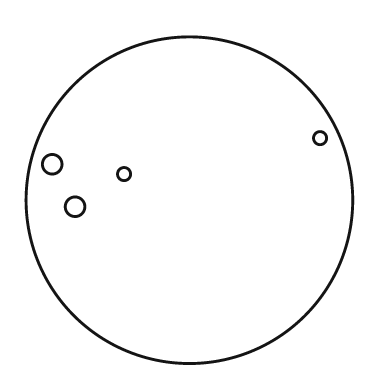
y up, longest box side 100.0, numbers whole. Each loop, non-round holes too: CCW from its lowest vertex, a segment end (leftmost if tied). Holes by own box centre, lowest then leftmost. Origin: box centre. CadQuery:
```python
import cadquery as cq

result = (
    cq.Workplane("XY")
    .moveTo(0.0, 0.0)
    .circle(50.0)
    .moveTo(-35.0, -2.0)
    .circle(3.0)
    .moveTo(-20.0, 8.0)
    .circle(2.0)
    .moveTo(-42.0, 11.0)
    .circle(3.0)
    .moveTo(40.0, 19.0)
    .circle(2.0)
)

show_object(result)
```